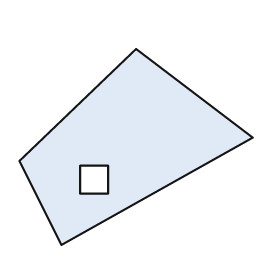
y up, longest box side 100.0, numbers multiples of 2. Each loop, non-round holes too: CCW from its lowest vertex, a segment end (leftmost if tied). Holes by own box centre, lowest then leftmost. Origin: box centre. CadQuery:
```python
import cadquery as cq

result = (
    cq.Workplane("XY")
    .moveTo(-32.0, -42.0)
    .lineTo(50.0, 4.0)
    .lineTo(0.0, 42.0)
    .lineTo(-50.0, -6.0)
    .close()
    .moveTo(-24.0, -20.0)
    .lineTo(-12.0, -20.0)
    .lineTo(-12.0, -8.0)
    .lineTo(-24.0, -8.0)
    .close()
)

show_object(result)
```